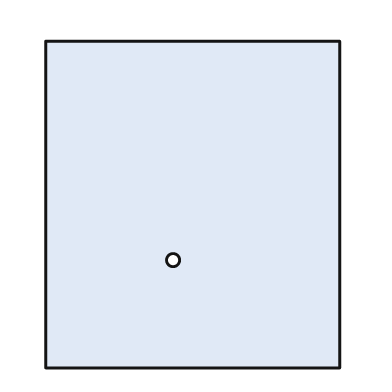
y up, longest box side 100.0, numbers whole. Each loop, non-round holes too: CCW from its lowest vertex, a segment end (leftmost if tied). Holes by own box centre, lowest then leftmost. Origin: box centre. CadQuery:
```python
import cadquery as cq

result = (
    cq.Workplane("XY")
    .moveTo(-45.0, -50.0)
    .lineTo(45.0, -50.0)
    .lineTo(45.0, 50.0)
    .lineTo(-45.0, 50.0)
    .close()
    .moveTo(-6.0, -17.0)
    .circle(2.0)
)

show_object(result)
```